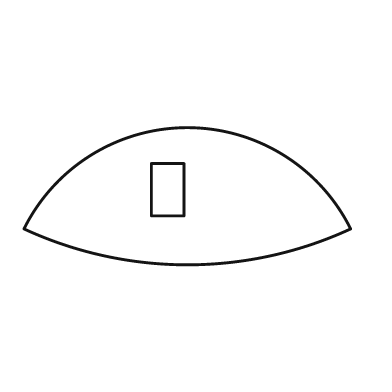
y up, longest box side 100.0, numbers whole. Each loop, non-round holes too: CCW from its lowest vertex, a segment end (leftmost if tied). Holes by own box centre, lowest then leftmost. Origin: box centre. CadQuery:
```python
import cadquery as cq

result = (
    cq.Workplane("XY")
    .moveTo(-50.0, -10.0)
    .threePointArc((0.0, -21.0), (50.0, -10.0))
    .threePointArc((0.0, 21.0), (-50.0, -10.0))
    .close()
    .moveTo(-11.0, -6.0)
    .lineTo(-1.0, -6.0)
    .lineTo(-1.0, 10.0)
    .lineTo(-11.0, 10.0)
    .close()
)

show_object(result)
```